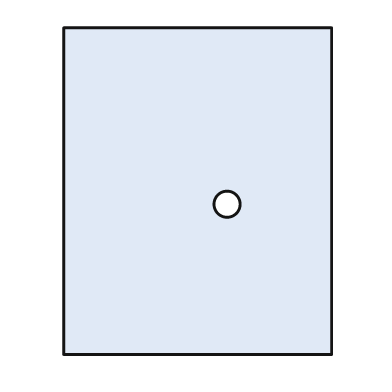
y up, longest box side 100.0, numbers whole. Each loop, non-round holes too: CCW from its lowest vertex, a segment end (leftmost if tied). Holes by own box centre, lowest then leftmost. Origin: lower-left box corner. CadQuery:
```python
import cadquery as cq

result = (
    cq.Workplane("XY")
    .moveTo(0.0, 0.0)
    .lineTo(82.0, 0.0)
    .lineTo(82.0, 100.0)
    .lineTo(0.0, 100.0)
    .close()
    .moveTo(50.0, 46.0)
    .circle(4.0)
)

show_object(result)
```